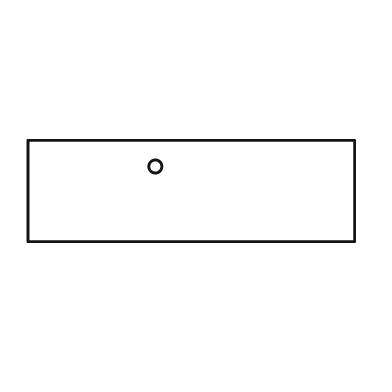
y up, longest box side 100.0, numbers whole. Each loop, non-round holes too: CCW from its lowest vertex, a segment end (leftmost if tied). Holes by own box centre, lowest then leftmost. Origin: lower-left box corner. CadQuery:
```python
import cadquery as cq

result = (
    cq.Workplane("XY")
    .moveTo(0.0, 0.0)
    .lineTo(100.0, 0.0)
    .lineTo(100.0, 31.0)
    .lineTo(0.0, 31.0)
    .close()
    .moveTo(39.0, 23.0)
    .circle(2.0)
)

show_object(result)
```